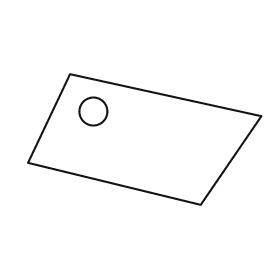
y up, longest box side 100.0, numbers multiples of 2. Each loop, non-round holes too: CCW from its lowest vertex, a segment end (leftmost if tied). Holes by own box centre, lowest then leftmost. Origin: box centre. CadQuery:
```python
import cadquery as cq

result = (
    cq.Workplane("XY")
    .moveTo(24.0, -28.0)
    .lineTo(50.0, 10.0)
    .lineTo(-32.0, 28.0)
    .lineTo(-50.0, -10.0)
    .close()
    .moveTo(-22.0, 12.0)
    .circle(6.0)
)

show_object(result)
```